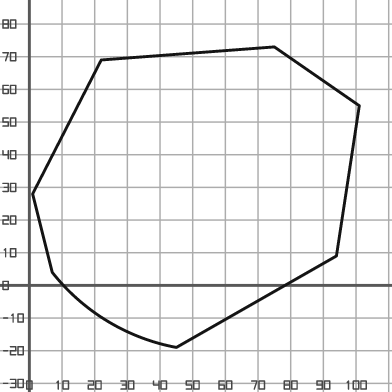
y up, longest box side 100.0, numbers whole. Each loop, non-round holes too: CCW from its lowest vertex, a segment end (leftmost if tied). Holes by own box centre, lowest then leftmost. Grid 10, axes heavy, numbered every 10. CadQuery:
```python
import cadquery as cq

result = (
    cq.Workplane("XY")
    .moveTo(45.0, -19.0)
    .lineTo(94.0, 9.0)
    .lineTo(101.0, 55.0)
    .lineTo(75.0, 73.0)
    .lineTo(22.0, 69.0)
    .lineTo(1.0, 28.0)
    .lineTo(7.0, 4.0)
    .threePointArc((24.0, -11.0), (45.0, -19.0))
    .close()
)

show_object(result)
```